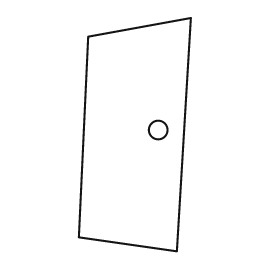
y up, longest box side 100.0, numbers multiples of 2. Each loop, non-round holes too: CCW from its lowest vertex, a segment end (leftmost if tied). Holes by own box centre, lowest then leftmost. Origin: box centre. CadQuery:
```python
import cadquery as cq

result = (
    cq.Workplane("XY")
    .moveTo(18.0, -50.0)
    .lineTo(24.0, 50.0)
    .lineTo(-20.0, 42.0)
    .lineTo(-24.0, -44.0)
    .close()
    .moveTo(10.0, 2.0)
    .circle(4.0)
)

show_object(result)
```